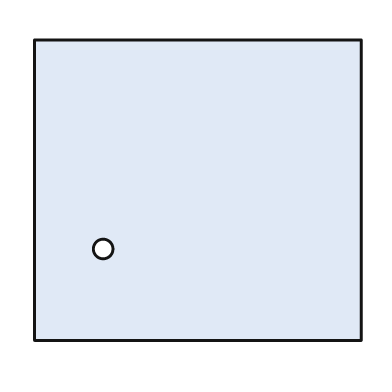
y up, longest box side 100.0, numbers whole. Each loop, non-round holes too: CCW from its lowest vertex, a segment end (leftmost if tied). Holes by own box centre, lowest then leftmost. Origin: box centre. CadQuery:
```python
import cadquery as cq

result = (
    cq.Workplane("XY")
    .moveTo(-50.0, -46.0)
    .lineTo(50.0, -46.0)
    .lineTo(50.0, 46.0)
    .lineTo(-50.0, 46.0)
    .close()
    .moveTo(-29.0, -18.0)
    .circle(3.0)
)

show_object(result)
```